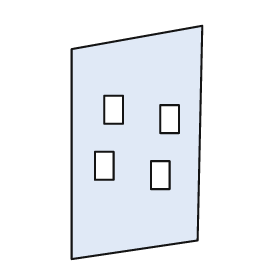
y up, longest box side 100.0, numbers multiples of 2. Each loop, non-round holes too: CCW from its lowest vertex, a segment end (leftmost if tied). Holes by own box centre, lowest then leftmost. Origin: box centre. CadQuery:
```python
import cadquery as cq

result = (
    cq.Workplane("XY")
    .moveTo(-28.0, -50.0)
    .lineTo(26.0, -42.0)
    .lineTo(28.0, 50.0)
    .lineTo(-28.0, 40.0)
    .close()
    .moveTo(6.0, -20.0)
    .lineTo(14.0, -20.0)
    .lineTo(14.0, -8.0)
    .lineTo(6.0, -8.0)
    .close()
    .moveTo(-18.0, -16.0)
    .lineTo(-10.0, -16.0)
    .lineTo(-10.0, -4.0)
    .lineTo(-18.0, -4.0)
    .close()
    .moveTo(10.0, 4.0)
    .lineTo(18.0, 4.0)
    .lineTo(18.0, 16.0)
    .lineTo(10.0, 16.0)
    .close()
    .moveTo(-14.0, 8.0)
    .lineTo(-6.0, 8.0)
    .lineTo(-6.0, 20.0)
    .lineTo(-14.0, 20.0)
    .close()
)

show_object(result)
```